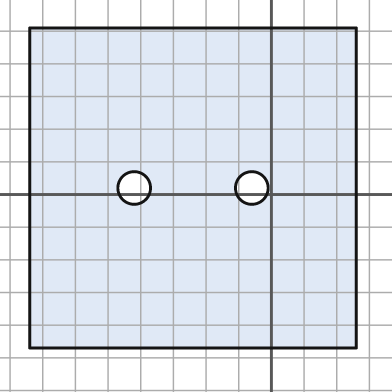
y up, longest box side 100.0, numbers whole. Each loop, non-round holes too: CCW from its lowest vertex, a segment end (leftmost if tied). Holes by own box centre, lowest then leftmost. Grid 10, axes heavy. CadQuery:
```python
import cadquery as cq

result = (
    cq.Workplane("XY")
    .moveTo(-74.0, -47.0)
    .lineTo(26.0, -47.0)
    .lineTo(26.0, 51.0)
    .lineTo(-74.0, 51.0)
    .close()
    .moveTo(-42.0, 2.0)
    .circle(5.0)
    .moveTo(-6.0, 2.0)
    .circle(5.0)
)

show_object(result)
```